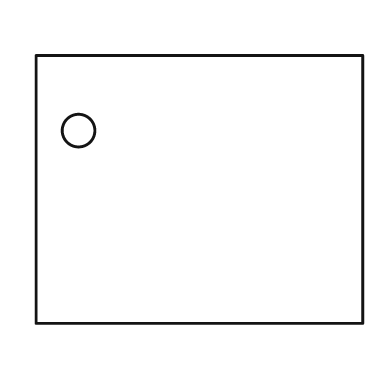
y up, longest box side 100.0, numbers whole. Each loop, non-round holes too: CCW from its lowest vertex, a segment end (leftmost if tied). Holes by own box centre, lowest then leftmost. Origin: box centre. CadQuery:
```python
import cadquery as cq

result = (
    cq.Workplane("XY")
    .moveTo(-50.0, -41.0)
    .lineTo(50.0, -41.0)
    .lineTo(50.0, 41.0)
    .lineTo(-50.0, 41.0)
    .close()
    .moveTo(-37.0, 18.0)
    .circle(5.0)
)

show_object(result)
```